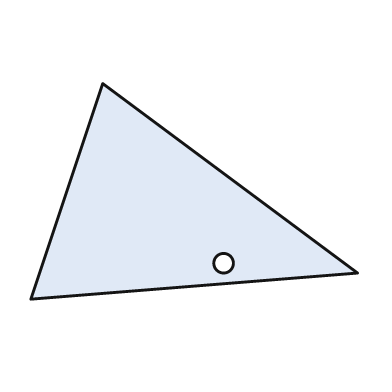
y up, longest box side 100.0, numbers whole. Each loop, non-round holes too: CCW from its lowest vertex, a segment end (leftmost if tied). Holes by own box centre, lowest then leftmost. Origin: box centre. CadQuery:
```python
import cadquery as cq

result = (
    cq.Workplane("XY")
    .moveTo(-50.0, -33.0)
    .lineTo(50.0, -25.0)
    .lineTo(-28.0, 33.0)
    .close()
    .moveTo(9.0, -22.0)
    .circle(3.0)
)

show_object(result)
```